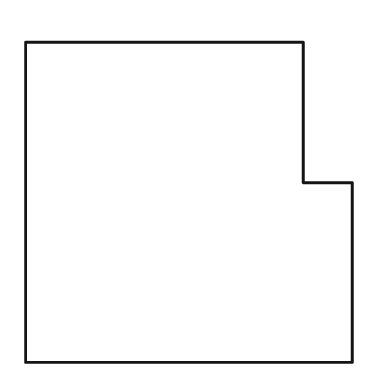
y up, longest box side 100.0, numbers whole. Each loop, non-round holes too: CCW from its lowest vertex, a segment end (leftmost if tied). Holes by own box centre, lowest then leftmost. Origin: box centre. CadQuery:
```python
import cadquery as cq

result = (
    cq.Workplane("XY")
    .moveTo(-50.0, -49.0)
    .lineTo(50.0, -49.0)
    .lineTo(50.0, 6.0)
    .lineTo(35.0, 6.0)
    .lineTo(35.0, 49.0)
    .lineTo(-50.0, 49.0)
    .close()
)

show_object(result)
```